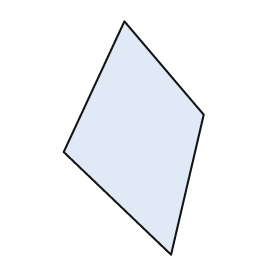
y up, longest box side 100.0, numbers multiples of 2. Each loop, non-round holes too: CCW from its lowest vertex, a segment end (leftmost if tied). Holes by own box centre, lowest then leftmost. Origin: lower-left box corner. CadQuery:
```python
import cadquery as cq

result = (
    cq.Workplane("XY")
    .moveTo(46.0, 0.0)
    .lineTo(60.0, 60.0)
    .lineTo(26.0, 100.0)
    .lineTo(0.0, 44.0)
    .close()
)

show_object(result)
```